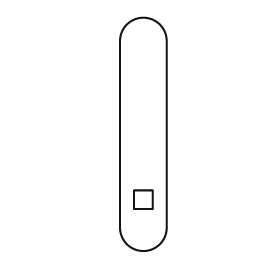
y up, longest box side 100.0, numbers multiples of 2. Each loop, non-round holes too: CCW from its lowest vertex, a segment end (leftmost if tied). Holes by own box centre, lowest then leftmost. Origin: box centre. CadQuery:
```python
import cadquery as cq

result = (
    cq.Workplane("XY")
    .moveTo(-10.0, -40.0)
    .threePointArc((0.0, -50.0), (10.0, -40.0))
    .lineTo(10.0, 40.0)
    .threePointArc((0.0, 50.0), (-10.0, 40.0))
    .close()
    .moveTo(-4.0, -32.0)
    .lineTo(4.0, -32.0)
    .lineTo(4.0, -24.0)
    .lineTo(-4.0, -24.0)
    .close()
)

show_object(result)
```